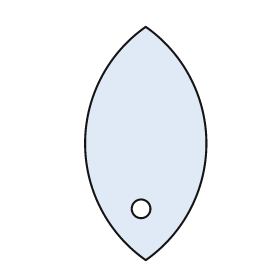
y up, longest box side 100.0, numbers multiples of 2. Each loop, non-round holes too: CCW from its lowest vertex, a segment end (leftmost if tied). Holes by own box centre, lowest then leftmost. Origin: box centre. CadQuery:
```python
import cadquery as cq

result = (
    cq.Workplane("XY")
    .moveTo(0.0, -50.0)
    .threePointArc((26.0, 0.0), (0.0, 50.0))
    .threePointArc((-26.0, 0.0), (0.0, -50.0))
    .close()
    .moveTo(-2.0, -28.0)
    .circle(4.0)
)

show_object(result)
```